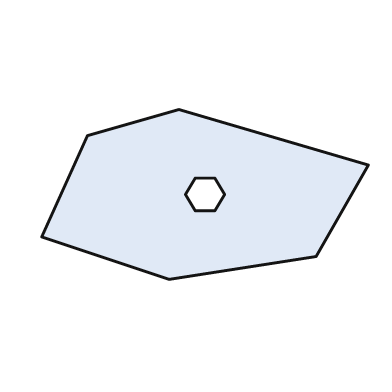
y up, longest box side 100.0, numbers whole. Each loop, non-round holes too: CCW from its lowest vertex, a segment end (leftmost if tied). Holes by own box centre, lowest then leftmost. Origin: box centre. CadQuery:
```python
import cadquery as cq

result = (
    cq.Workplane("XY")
    .moveTo(-11.0, -26.0)
    .lineTo(34.0, -19.0)
    .lineTo(50.0, 9.0)
    .lineTo(-8.0, 26.0)
    .lineTo(-36.0, 18.0)
    .lineTo(-50.0, -13.0)
    .close()
    .moveTo(-3.0, -5.0)
    .lineTo(3.0, -5.0)
    .lineTo(6.0, 0.0)
    .lineTo(3.0, 5.0)
    .lineTo(-3.0, 5.0)
    .lineTo(-6.0, 0.0)
    .close()
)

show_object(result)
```